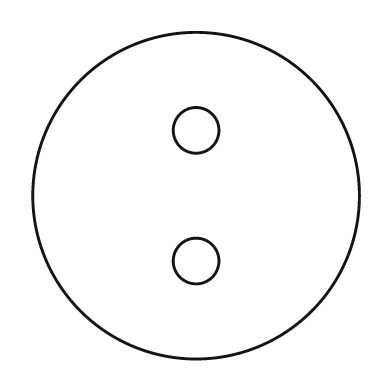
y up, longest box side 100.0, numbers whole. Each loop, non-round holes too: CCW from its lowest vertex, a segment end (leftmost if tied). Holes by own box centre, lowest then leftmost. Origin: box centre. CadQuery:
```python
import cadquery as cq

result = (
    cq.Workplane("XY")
    .moveTo(0.0, 0.0)
    .circle(50.0)
    .moveTo(0.0, -20.0)
    .circle(7.0)
    .moveTo(0.0, 20.0)
    .circle(7.0)
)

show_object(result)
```